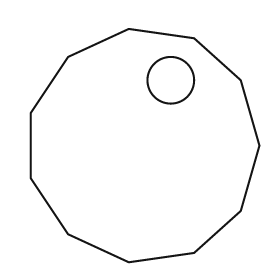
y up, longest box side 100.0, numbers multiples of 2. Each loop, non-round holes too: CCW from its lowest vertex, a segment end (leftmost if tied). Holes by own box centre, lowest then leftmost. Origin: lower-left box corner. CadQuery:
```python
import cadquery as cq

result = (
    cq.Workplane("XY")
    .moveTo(42.0, 0.0)
    .lineTo(70.0, 4.0)
    .lineTo(90.0, 22.0)
    .lineTo(98.0, 50.0)
    .lineTo(90.0, 78.0)
    .lineTo(70.0, 96.0)
    .lineTo(42.0, 100.0)
    .lineTo(16.0, 88.0)
    .lineTo(0.0, 64.0)
    .lineTo(0.0, 36.0)
    .lineTo(16.0, 12.0)
    .close()
    .moveTo(60.0, 78.0)
    .circle(10.0)
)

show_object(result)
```